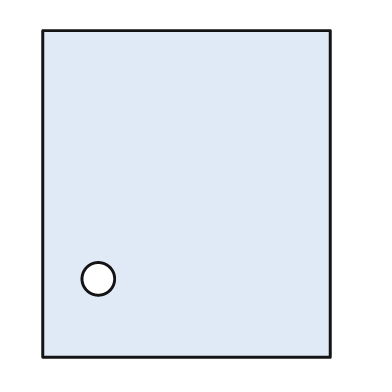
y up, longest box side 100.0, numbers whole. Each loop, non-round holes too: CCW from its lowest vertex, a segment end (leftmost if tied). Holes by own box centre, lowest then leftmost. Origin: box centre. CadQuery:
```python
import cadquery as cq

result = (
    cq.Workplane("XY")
    .moveTo(-44.0, -50.0)
    .lineTo(44.0, -50.0)
    .lineTo(44.0, 50.0)
    .lineTo(-44.0, 50.0)
    .close()
    .moveTo(-27.0, -26.0)
    .circle(5.0)
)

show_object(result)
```